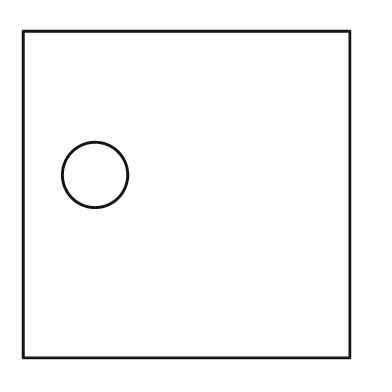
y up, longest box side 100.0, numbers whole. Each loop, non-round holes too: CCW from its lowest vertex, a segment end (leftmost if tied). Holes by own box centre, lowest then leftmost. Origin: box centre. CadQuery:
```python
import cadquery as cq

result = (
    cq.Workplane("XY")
    .moveTo(-50.0, -50.0)
    .lineTo(50.0, -50.0)
    .lineTo(50.0, 50.0)
    .lineTo(-50.0, 50.0)
    .close()
    .moveTo(-28.0, 6.0)
    .circle(10.0)
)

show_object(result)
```